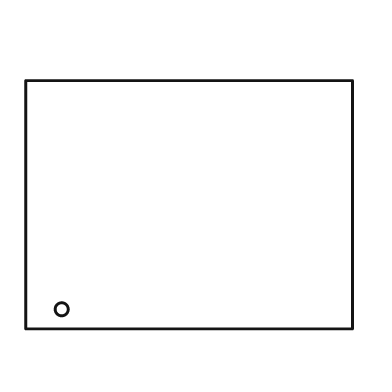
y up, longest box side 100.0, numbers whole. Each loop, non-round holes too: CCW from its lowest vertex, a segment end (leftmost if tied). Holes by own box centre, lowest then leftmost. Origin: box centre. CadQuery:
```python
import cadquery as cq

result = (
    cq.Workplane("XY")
    .moveTo(-50.0, -38.0)
    .lineTo(50.0, -38.0)
    .lineTo(50.0, 38.0)
    .lineTo(-50.0, 38.0)
    .close()
    .moveTo(-39.0, -32.0)
    .circle(2.0)
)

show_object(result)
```